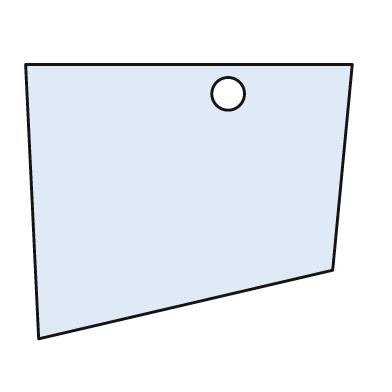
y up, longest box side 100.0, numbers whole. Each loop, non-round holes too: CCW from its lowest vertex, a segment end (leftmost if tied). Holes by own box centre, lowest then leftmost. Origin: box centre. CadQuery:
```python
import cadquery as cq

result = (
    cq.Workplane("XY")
    .moveTo(-46.0, -42.0)
    .lineTo(44.0, -21.0)
    .lineTo(50.0, 42.0)
    .lineTo(-50.0, 42.0)
    .close()
    .moveTo(12.0, 33.0)
    .circle(5.0)
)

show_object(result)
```